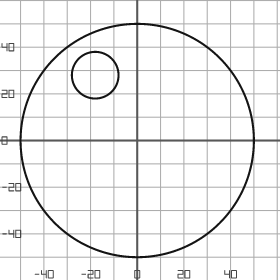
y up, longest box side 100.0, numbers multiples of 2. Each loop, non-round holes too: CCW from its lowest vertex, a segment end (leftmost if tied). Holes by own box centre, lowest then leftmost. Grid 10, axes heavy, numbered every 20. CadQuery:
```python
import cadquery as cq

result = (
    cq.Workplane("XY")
    .moveTo(0.0, 0.0)
    .circle(50.0)
    .moveTo(-18.0, 28.0)
    .circle(10.0)
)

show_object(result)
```